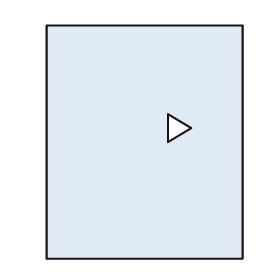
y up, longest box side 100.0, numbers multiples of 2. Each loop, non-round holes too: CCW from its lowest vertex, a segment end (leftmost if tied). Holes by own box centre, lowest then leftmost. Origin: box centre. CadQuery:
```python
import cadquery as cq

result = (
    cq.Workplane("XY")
    .moveTo(-42.0, -50.0)
    .lineTo(42.0, -50.0)
    .lineTo(42.0, 50.0)
    .lineTo(-42.0, 50.0)
    .close()
    .moveTo(10.0, 0.0)
    .lineTo(20.0, 6.0)
    .lineTo(10.0, 12.0)
    .close()
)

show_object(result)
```